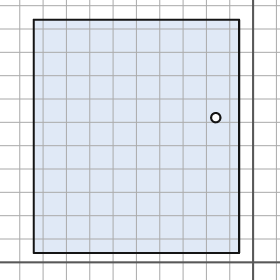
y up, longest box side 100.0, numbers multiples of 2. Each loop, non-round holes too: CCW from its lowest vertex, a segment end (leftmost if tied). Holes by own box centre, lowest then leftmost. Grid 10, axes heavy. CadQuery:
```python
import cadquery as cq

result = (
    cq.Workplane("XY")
    .moveTo(-94.0, 4.0)
    .lineTo(-6.0, 4.0)
    .lineTo(-6.0, 104.0)
    .lineTo(-94.0, 104.0)
    .close()
    .moveTo(-16.0, 62.0)
    .circle(2.0)
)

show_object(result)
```